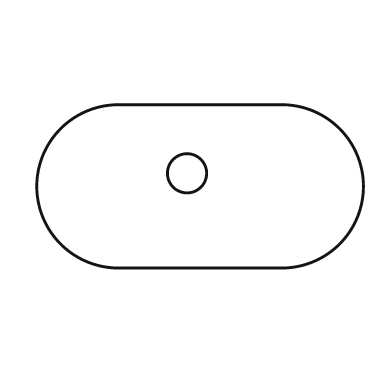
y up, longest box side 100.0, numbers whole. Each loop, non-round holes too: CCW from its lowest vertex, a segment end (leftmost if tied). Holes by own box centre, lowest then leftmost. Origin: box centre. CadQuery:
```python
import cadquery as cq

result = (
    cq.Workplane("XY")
    .moveTo(-25.0, -25.0)
    .lineTo(25.0, -25.0)
    .threePointArc((50.0, 0.0), (25.0, 25.0))
    .lineTo(-25.0, 25.0)
    .threePointArc((-50.0, 0.0), (-25.0, -25.0))
    .close()
    .moveTo(-4.0, 4.0)
    .circle(6.0)
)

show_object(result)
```